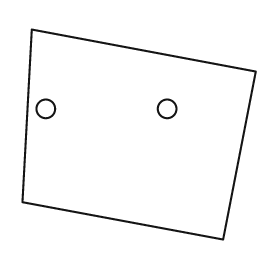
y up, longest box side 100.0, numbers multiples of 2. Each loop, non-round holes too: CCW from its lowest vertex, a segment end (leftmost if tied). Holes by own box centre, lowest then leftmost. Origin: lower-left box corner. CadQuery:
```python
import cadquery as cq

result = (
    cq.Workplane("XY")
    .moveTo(86.0, 0.0)
    .lineTo(100.0, 72.0)
    .lineTo(4.0, 90.0)
    .lineTo(0.0, 16.0)
    .close()
    .moveTo(10.0, 56.0)
    .circle(4.0)
    .moveTo(62.0, 56.0)
    .circle(4.0)
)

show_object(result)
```